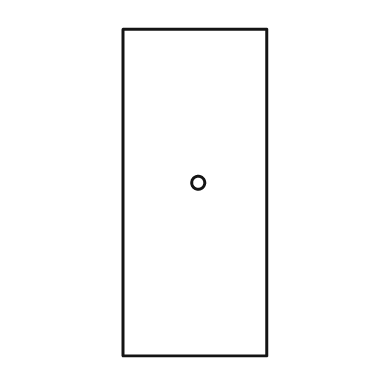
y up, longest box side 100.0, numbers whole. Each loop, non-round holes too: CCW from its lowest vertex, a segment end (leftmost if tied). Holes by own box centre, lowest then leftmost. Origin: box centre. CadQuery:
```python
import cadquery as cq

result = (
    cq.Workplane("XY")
    .moveTo(-22.0, -50.0)
    .lineTo(22.0, -50.0)
    .lineTo(22.0, 50.0)
    .lineTo(-22.0, 50.0)
    .close()
    .moveTo(1.0, 3.0)
    .circle(2.0)
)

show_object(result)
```